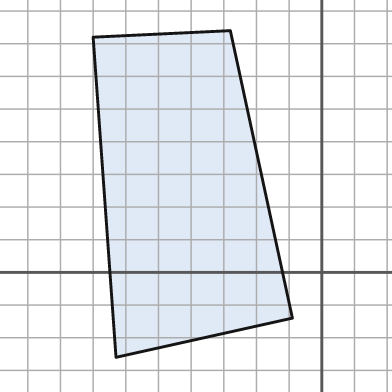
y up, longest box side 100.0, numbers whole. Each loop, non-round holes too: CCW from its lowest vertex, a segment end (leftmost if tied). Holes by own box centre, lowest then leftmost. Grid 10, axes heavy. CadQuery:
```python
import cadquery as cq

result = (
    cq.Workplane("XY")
    .moveTo(-63.0, -26.0)
    .lineTo(-9.0, -14.0)
    .lineTo(-28.0, 74.0)
    .lineTo(-70.0, 72.0)
    .close()
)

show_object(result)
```